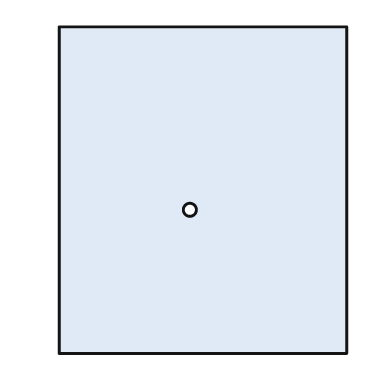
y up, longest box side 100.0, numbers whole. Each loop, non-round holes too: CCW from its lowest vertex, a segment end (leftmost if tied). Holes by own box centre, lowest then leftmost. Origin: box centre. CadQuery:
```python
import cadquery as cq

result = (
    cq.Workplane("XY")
    .moveTo(-44.0, -50.0)
    .lineTo(44.0, -50.0)
    .lineTo(44.0, 50.0)
    .lineTo(-44.0, 50.0)
    .close()
    .moveTo(-4.0, -6.0)
    .circle(2.0)
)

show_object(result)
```